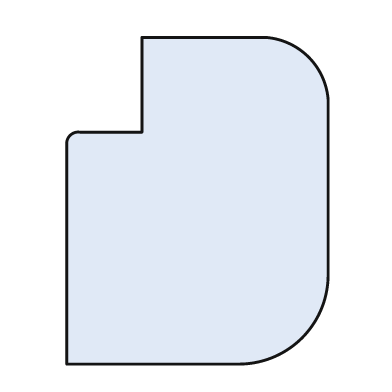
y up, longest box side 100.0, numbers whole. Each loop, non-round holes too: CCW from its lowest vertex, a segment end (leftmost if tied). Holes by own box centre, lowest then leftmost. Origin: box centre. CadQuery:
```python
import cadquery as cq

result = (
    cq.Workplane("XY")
    .moveTo(-40.0, -50.0)
    .lineTo(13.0, -50.0)
    .threePointArc((32.0, -42.0), (40.0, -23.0))
    .lineTo(40.0, 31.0)
    .threePointArc((34.0, 44.0), (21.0, 50.0))
    .lineTo(-17.0, 50.0)
    .lineTo(-17.0, 21.0)
    .lineTo(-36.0, 21.0)
    .threePointArc((-39.0, 20.0), (-40.0, 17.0))
    .close()
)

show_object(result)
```